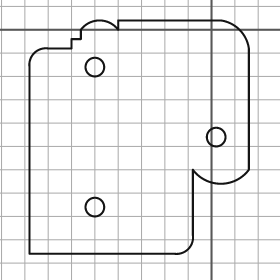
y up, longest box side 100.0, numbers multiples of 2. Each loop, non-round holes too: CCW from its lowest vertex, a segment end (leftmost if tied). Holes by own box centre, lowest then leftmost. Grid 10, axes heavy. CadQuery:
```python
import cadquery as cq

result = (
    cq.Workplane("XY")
    .moveTo(-78.0, -96.0)
    .lineTo(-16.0, -96.0)
    .threePointArc((-10.0, -94.0), (-8.0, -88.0))
    .lineTo(-8.0, -60.0)
    .threePointArc((4.0, -66.0), (16.0, -60.0))
    .lineTo(16.0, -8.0)
    .threePointArc((12.0, 0.0), (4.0, 4.0))
    .lineTo(-40.0, 4.0)
    .lineTo(-40.0, 0.0)
    .threePointArc((-48.0, 4.0), (-56.0, 0.0))
    .lineTo(-56.0, -4.0)
    .lineTo(-60.0, -4.0)
    .lineTo(-60.0, -8.0)
    .lineTo(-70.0, -8.0)
    .threePointArc((-76.0, -10.0), (-78.0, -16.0))
    .close()
    .moveTo(-50.0, -76.0)
    .circle(4.0)
    .moveTo(2.0, -46.0)
    .circle(4.0)
    .moveTo(-50.0, -16.0)
    .circle(4.0)
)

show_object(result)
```